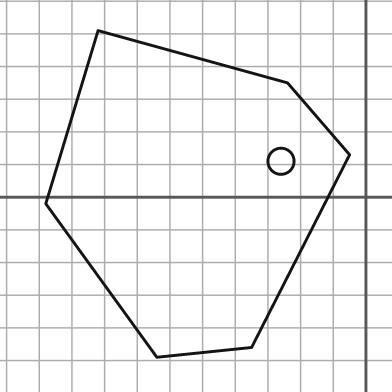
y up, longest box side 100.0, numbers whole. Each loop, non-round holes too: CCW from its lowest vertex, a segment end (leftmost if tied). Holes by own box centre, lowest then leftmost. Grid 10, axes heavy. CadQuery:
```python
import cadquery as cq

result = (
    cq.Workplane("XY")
    .moveTo(-64.0, -49.0)
    .lineTo(-35.0, -46.0)
    .lineTo(-5.0, 13.0)
    .lineTo(-24.0, 35.0)
    .lineTo(-82.0, 51.0)
    .lineTo(-98.0, -2.0)
    .close()
    .moveTo(-26.0, 11.0)
    .circle(4.0)
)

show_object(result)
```